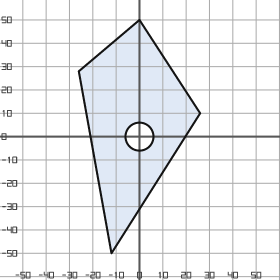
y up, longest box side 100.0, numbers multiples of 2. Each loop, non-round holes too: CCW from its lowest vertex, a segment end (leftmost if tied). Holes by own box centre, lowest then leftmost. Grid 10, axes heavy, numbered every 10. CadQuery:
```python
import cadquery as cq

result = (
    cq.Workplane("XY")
    .moveTo(-12.0, -50.0)
    .lineTo(26.0, 10.0)
    .lineTo(0.0, 50.0)
    .lineTo(-26.0, 28.0)
    .close()
    .moveTo(0.0, 0.0)
    .circle(6.0)
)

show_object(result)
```